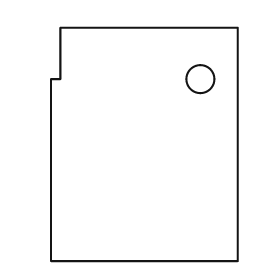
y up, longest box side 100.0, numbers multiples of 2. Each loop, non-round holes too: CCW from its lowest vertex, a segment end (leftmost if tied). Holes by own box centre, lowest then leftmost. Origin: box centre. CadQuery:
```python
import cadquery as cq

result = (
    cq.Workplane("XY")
    .moveTo(-40.0, -50.0)
    .lineTo(40.0, -50.0)
    .lineTo(40.0, 50.0)
    .lineTo(-36.0, 50.0)
    .lineTo(-36.0, 28.0)
    .lineTo(-40.0, 28.0)
    .close()
    .moveTo(24.0, 28.0)
    .circle(6.0)
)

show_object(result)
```